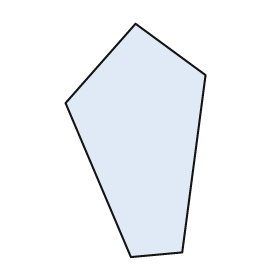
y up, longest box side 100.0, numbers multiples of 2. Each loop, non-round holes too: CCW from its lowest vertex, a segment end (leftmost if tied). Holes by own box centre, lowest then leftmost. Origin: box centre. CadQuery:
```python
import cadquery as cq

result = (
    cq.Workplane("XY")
    .moveTo(-2.0, -50.0)
    .lineTo(20.0, -48.0)
    .lineTo(30.0, 28.0)
    .lineTo(0.0, 50.0)
    .lineTo(-30.0, 16.0)
    .close()
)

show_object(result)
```